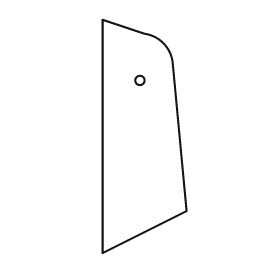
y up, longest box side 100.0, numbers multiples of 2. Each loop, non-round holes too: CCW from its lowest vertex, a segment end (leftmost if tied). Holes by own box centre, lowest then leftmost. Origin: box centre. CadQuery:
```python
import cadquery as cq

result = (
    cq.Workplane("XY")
    .moveTo(-18.0, -50.0)
    .lineTo(18.0, -32.0)
    .lineTo(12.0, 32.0)
    .threePointArc((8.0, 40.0), (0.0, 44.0))
    .lineTo(-18.0, 50.0)
    .close()
    .moveTo(-2.0, 24.0)
    .circle(2.0)
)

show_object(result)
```